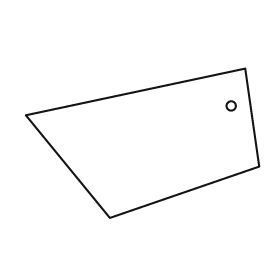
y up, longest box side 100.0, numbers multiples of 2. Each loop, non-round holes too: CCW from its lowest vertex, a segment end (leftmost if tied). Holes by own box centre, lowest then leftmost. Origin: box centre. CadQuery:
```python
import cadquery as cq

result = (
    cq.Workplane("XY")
    .moveTo(-14.0, -32.0)
    .lineTo(50.0, -10.0)
    .lineTo(44.0, 32.0)
    .lineTo(-50.0, 12.0)
    .close()
    .moveTo(38.0, 16.0)
    .circle(2.0)
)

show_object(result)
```